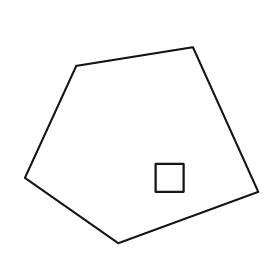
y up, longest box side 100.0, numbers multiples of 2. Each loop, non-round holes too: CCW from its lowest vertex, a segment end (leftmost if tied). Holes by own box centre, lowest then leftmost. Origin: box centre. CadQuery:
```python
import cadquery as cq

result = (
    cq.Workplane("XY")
    .moveTo(-10.0, -42.0)
    .lineTo(50.0, -20.0)
    .lineTo(22.0, 42.0)
    .lineTo(-28.0, 34.0)
    .lineTo(-50.0, -14.0)
    .close()
    .moveTo(6.0, -20.0)
    .lineTo(18.0, -20.0)
    .lineTo(18.0, -8.0)
    .lineTo(6.0, -8.0)
    .close()
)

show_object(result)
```